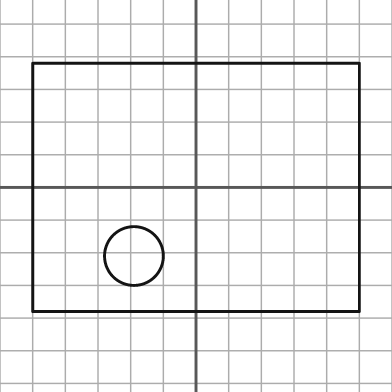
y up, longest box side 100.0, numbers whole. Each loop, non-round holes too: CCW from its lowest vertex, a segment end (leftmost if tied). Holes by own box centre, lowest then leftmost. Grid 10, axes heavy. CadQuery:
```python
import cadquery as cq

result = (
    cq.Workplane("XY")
    .moveTo(-50.0, -38.0)
    .lineTo(50.0, -38.0)
    .lineTo(50.0, 38.0)
    .lineTo(-50.0, 38.0)
    .close()
    .moveTo(-19.0, -21.0)
    .circle(9.0)
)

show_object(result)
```